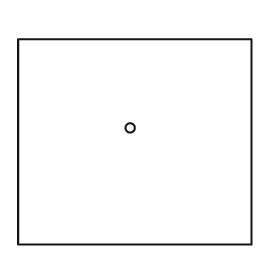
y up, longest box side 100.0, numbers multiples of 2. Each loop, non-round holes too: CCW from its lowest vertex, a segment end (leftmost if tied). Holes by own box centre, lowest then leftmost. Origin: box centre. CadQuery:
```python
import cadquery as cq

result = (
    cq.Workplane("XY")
    .moveTo(-50.0, -44.0)
    .lineTo(50.0, -44.0)
    .lineTo(50.0, 44.0)
    .lineTo(-50.0, 44.0)
    .close()
    .moveTo(-2.0, 6.0)
    .circle(2.0)
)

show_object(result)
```